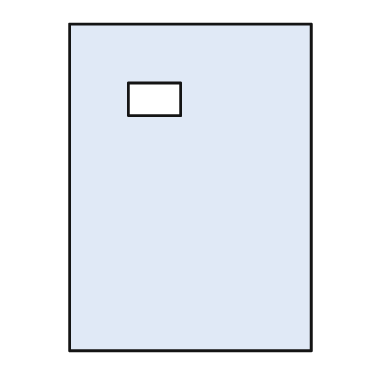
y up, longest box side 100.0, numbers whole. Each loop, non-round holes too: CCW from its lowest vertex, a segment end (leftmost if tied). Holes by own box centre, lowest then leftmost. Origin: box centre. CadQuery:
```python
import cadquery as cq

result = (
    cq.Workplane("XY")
    .moveTo(-37.0, -50.0)
    .lineTo(37.0, -50.0)
    .lineTo(37.0, 50.0)
    .lineTo(-37.0, 50.0)
    .close()
    .moveTo(-19.0, 22.0)
    .lineTo(-3.0, 22.0)
    .lineTo(-3.0, 32.0)
    .lineTo(-19.0, 32.0)
    .close()
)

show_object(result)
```